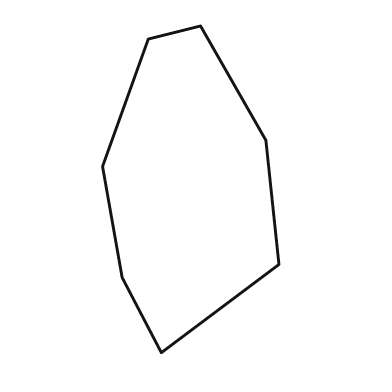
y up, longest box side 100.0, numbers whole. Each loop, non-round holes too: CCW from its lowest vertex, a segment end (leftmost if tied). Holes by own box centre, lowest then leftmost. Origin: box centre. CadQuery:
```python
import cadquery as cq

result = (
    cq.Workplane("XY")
    .moveTo(-9.0, -50.0)
    .lineTo(27.0, -23.0)
    .lineTo(23.0, 15.0)
    .lineTo(3.0, 50.0)
    .lineTo(-13.0, 46.0)
    .lineTo(-27.0, 7.0)
    .lineTo(-21.0, -27.0)
    .close()
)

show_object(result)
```